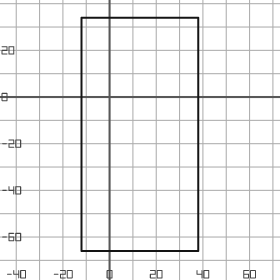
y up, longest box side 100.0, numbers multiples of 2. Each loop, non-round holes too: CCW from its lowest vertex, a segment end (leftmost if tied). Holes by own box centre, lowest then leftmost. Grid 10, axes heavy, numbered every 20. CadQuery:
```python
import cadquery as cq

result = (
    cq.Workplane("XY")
    .moveTo(-12.0, -66.0)
    .lineTo(38.0, -66.0)
    .lineTo(38.0, 34.0)
    .lineTo(-12.0, 34.0)
    .close()
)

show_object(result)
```